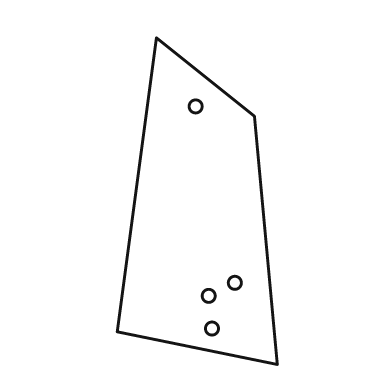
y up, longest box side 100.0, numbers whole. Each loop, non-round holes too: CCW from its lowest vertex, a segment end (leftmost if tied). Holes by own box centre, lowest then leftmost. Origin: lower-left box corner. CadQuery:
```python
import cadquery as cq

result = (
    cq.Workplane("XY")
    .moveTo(49.0, 0.0)
    .lineTo(42.0, 76.0)
    .lineTo(12.0, 100.0)
    .lineTo(0.0, 10.0)
    .close()
    .moveTo(29.0, 11.0)
    .circle(2.0)
    .moveTo(28.0, 21.0)
    .circle(2.0)
    .moveTo(36.0, 25.0)
    .circle(2.0)
    .moveTo(24.0, 79.0)
    .circle(2.0)
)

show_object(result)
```